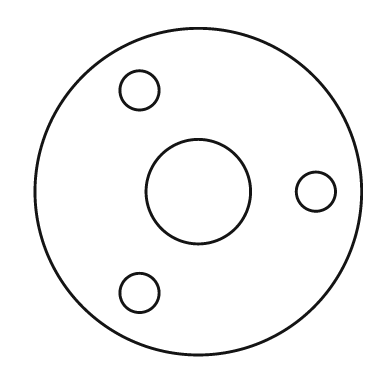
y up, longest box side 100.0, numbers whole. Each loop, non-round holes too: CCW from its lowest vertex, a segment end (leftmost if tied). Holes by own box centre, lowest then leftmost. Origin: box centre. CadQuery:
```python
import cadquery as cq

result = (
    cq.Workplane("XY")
    .moveTo(0.0, 0.0)
    .circle(50.0)
    .moveTo(-18.0, -31.0)
    .circle(6.0)
    .moveTo(0.0, 0.0)
    .circle(16.0)
    .moveTo(36.0, 0.0)
    .circle(6.0)
    .moveTo(-18.0, 31.0)
    .circle(6.0)
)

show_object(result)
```